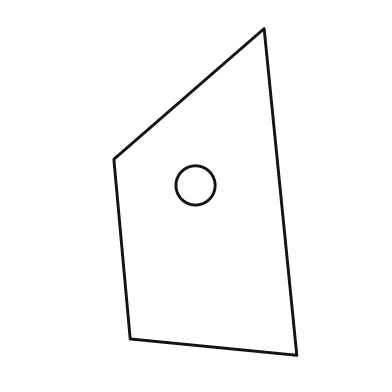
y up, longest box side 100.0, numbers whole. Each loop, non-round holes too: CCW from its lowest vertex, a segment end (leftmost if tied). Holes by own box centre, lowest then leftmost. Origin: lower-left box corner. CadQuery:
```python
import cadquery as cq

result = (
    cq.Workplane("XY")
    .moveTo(56.0, 0.0)
    .lineTo(46.0, 100.0)
    .lineTo(0.0, 60.0)
    .lineTo(5.0, 5.0)
    .close()
    .moveTo(25.0, 52.0)
    .circle(6.0)
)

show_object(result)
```